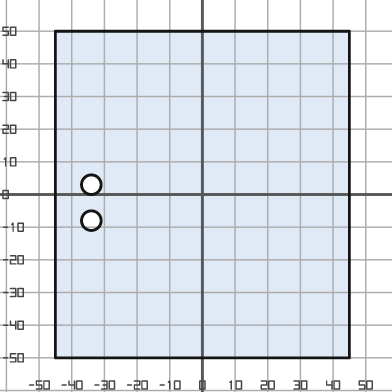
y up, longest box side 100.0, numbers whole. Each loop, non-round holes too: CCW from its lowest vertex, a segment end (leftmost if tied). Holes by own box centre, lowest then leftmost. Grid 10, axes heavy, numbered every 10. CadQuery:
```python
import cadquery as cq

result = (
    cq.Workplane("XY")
    .moveTo(-45.0, -50.0)
    .lineTo(45.0, -50.0)
    .lineTo(45.0, 50.0)
    .lineTo(-45.0, 50.0)
    .close()
    .moveTo(-34.0, -8.0)
    .circle(3.0)
    .moveTo(-34.0, 3.0)
    .circle(3.0)
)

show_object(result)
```